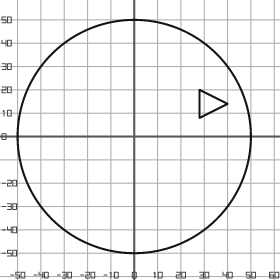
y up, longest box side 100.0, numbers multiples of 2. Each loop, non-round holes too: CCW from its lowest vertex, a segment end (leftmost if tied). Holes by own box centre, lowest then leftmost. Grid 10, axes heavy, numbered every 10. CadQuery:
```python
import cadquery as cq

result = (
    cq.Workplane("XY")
    .moveTo(0.0, 0.0)
    .circle(50.0)
    .moveTo(28.0, 8.0)
    .lineTo(40.0, 14.0)
    .lineTo(28.0, 20.0)
    .close()
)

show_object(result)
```